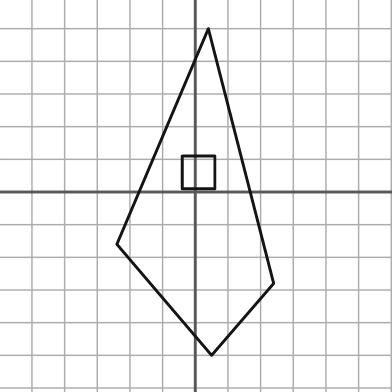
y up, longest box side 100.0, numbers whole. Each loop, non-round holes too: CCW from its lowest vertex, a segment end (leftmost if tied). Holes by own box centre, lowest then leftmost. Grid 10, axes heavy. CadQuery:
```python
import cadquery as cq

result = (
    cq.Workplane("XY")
    .moveTo(5.0, -50.0)
    .lineTo(24.0, -28.0)
    .lineTo(4.0, 50.0)
    .lineTo(-24.0, -16.0)
    .close()
    .moveTo(-4.0, 1.0)
    .lineTo(6.0, 1.0)
    .lineTo(6.0, 11.0)
    .lineTo(-4.0, 11.0)
    .close()
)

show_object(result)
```